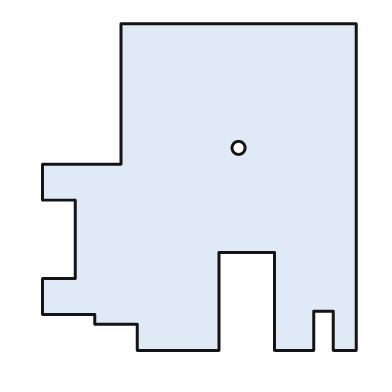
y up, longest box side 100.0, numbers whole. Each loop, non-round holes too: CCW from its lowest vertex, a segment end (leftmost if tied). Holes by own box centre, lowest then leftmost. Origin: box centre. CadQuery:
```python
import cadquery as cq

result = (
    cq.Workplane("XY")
    .moveTo(-19.0, -50.0)
    .lineTo(6.0, -50.0)
    .lineTo(6.0, -20.0)
    .lineTo(23.0, -20.0)
    .lineTo(23.0, -50.0)
    .lineTo(35.0, -50.0)
    .lineTo(35.0, -38.0)
    .lineTo(41.0, -38.0)
    .lineTo(41.0, -50.0)
    .lineTo(48.0, -50.0)
    .lineTo(48.0, 50.0)
    .lineTo(-24.0, 50.0)
    .lineTo(-24.0, 7.0)
    .lineTo(-48.0, 7.0)
    .lineTo(-48.0, -4.0)
    .lineTo(-38.0, -4.0)
    .lineTo(-38.0, -28.0)
    .lineTo(-48.0, -28.0)
    .lineTo(-48.0, -39.0)
    .lineTo(-32.0, -39.0)
    .lineTo(-32.0, -42.0)
    .lineTo(-19.0, -42.0)
    .close()
    .moveTo(12.0, 12.0)
    .circle(2.0)
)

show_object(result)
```